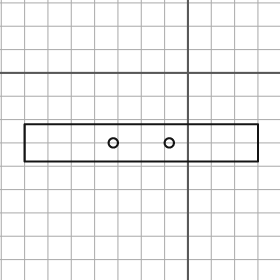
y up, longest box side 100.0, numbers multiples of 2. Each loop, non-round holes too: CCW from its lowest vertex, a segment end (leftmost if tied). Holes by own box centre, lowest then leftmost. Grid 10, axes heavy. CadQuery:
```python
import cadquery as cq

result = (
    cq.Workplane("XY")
    .moveTo(-70.0, -38.0)
    .lineTo(30.0, -38.0)
    .lineTo(30.0, -22.0)
    .lineTo(-70.0, -22.0)
    .close()
    .moveTo(-32.0, -30.0)
    .circle(2.0)
    .moveTo(-8.0, -30.0)
    .circle(2.0)
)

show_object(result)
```